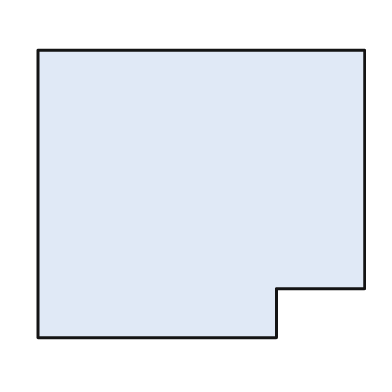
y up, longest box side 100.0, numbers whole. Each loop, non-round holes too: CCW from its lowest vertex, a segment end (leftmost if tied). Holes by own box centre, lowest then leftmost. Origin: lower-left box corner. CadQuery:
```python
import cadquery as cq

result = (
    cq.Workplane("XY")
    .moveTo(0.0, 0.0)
    .lineTo(73.0, 0.0)
    .lineTo(73.0, 15.0)
    .lineTo(100.0, 15.0)
    .lineTo(100.0, 88.0)
    .lineTo(0.0, 88.0)
    .close()
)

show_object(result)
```